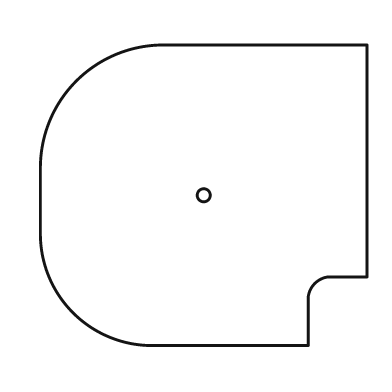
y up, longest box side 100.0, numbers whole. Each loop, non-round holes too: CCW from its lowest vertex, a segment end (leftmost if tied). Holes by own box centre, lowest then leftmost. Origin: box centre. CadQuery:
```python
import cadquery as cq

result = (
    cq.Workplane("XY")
    .moveTo(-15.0, -46.0)
    .lineTo(32.0, -46.0)
    .lineTo(32.0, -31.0)
    .threePointArc((34.0, -27.0), (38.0, -25.0))
    .lineTo(50.0, -25.0)
    .lineTo(50.0, 46.0)
    .lineTo(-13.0, 46.0)
    .threePointArc((-39.0, 35.0), (-50.0, 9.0))
    .lineTo(-50.0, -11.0)
    .threePointArc((-40.0, -36.0), (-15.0, -46.0))
    .close()
    .moveTo(0.0, 0.0)
    .circle(2.0)
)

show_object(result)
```